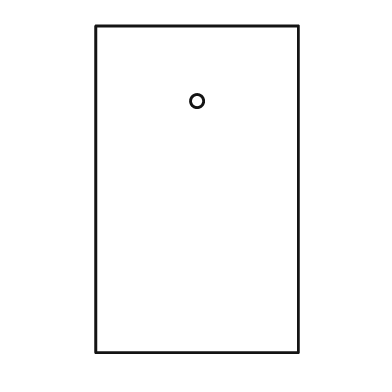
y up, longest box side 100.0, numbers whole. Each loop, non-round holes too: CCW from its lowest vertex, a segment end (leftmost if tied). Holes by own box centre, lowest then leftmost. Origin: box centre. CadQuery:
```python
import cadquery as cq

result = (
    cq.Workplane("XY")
    .moveTo(-31.0, -50.0)
    .lineTo(31.0, -50.0)
    .lineTo(31.0, 50.0)
    .lineTo(-31.0, 50.0)
    .close()
    .moveTo(0.0, 27.0)
    .circle(2.0)
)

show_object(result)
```